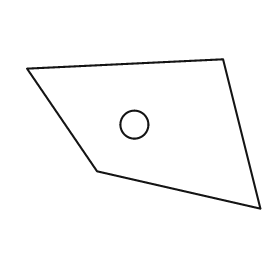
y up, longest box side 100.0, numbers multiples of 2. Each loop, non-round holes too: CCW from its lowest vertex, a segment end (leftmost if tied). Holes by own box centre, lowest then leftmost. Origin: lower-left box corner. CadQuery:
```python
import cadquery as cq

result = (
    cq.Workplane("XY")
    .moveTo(100.0, 0.0)
    .lineTo(84.0, 64.0)
    .lineTo(0.0, 60.0)
    .lineTo(30.0, 16.0)
    .close()
    .moveTo(46.0, 36.0)
    .circle(6.0)
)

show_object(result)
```